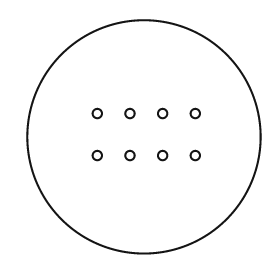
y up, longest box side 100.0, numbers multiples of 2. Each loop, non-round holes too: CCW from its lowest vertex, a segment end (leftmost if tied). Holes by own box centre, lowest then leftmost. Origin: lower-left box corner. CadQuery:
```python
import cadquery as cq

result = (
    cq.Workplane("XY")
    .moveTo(50.0, 50.0)
    .circle(50.0)
    .moveTo(30.0, 42.0)
    .circle(2.0)
    .moveTo(44.0, 42.0)
    .circle(2.0)
    .moveTo(58.0, 42.0)
    .circle(2.0)
    .moveTo(72.0, 42.0)
    .circle(2.0)
    .moveTo(30.0, 60.0)
    .circle(2.0)
    .moveTo(44.0, 60.0)
    .circle(2.0)
    .moveTo(58.0, 60.0)
    .circle(2.0)
    .moveTo(72.0, 60.0)
    .circle(2.0)
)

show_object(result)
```